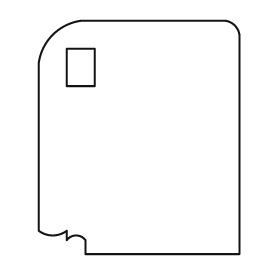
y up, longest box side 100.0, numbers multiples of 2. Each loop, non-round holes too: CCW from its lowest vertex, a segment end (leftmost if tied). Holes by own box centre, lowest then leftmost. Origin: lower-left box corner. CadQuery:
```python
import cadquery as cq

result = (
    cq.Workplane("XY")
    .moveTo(20.0, 0.0)
    .lineTo(86.0, 0.0)
    .lineTo(86.0, 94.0)
    .threePointArc((84.0, 98.0), (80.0, 100.0))
    .lineTo(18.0, 100.0)
    .threePointArc((6.0, 94.0), (0.0, 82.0))
    .lineTo(0.0, 10.0)
    .threePointArc((6.0, 8.0), (12.0, 10.0))
    .lineTo(12.0, 6.0)
    .threePointArc((16.0, 8.0), (20.0, 6.0))
    .close()
    .moveTo(12.0, 72.0)
    .lineTo(24.0, 72.0)
    .lineTo(24.0, 88.0)
    .lineTo(12.0, 88.0)
    .close()
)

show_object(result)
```